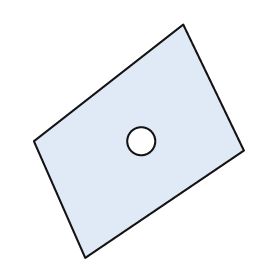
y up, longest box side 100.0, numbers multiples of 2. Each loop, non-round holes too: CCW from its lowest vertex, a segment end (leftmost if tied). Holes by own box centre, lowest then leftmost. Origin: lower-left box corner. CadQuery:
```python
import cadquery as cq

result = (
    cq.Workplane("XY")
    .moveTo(22.0, 0.0)
    .lineTo(90.0, 46.0)
    .lineTo(64.0, 100.0)
    .lineTo(0.0, 50.0)
    .close()
    .moveTo(46.0, 50.0)
    .circle(6.0)
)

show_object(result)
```